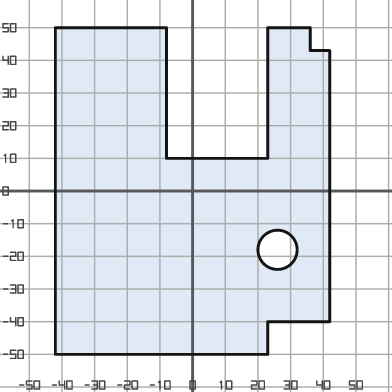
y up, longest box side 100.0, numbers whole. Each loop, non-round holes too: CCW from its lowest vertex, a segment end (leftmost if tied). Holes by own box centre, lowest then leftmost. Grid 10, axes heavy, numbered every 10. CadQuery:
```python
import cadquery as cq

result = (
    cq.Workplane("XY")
    .moveTo(-42.0, -50.0)
    .lineTo(23.0, -50.0)
    .lineTo(23.0, -40.0)
    .lineTo(42.0, -40.0)
    .lineTo(42.0, 43.0)
    .lineTo(36.0, 43.0)
    .lineTo(36.0, 50.0)
    .lineTo(23.0, 50.0)
    .lineTo(23.0, 10.0)
    .lineTo(-8.0, 10.0)
    .lineTo(-8.0, 50.0)
    .lineTo(-42.0, 50.0)
    .close()
    .moveTo(26.0, -18.0)
    .circle(6.0)
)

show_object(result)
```